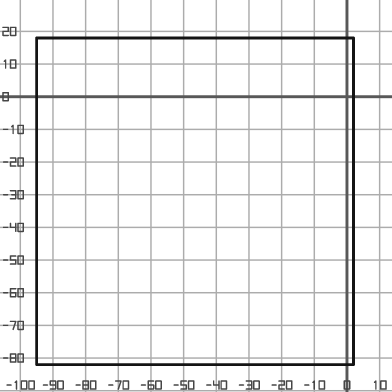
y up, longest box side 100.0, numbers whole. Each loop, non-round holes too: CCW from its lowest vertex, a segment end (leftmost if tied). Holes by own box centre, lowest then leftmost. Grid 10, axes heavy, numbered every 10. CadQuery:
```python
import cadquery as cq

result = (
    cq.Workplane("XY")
    .moveTo(-95.0, -82.0)
    .lineTo(2.0, -82.0)
    .lineTo(2.0, 18.0)
    .lineTo(-95.0, 18.0)
    .close()
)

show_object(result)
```